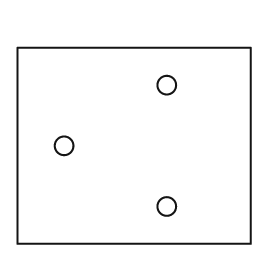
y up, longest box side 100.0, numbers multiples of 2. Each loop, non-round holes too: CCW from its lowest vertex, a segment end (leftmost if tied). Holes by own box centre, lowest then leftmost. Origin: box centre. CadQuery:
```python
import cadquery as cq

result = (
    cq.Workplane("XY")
    .moveTo(-50.0, -42.0)
    .lineTo(50.0, -42.0)
    .lineTo(50.0, 42.0)
    .lineTo(-50.0, 42.0)
    .close()
    .moveTo(14.0, -26.0)
    .circle(4.0)
    .moveTo(-30.0, 0.0)
    .circle(4.0)
    .moveTo(14.0, 26.0)
    .circle(4.0)
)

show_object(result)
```